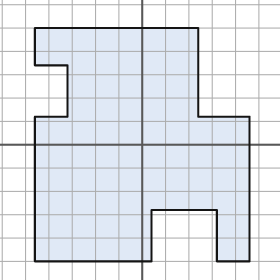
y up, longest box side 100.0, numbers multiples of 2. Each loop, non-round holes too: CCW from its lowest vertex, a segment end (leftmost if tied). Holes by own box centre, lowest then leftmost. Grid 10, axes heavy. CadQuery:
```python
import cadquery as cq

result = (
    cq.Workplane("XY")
    .moveTo(-46.0, -50.0)
    .lineTo(4.0, -50.0)
    .lineTo(4.0, -28.0)
    .lineTo(32.0, -28.0)
    .lineTo(32.0, -50.0)
    .lineTo(46.0, -50.0)
    .lineTo(46.0, 12.0)
    .lineTo(24.0, 12.0)
    .lineTo(24.0, 50.0)
    .lineTo(-46.0, 50.0)
    .lineTo(-46.0, 34.0)
    .lineTo(-32.0, 34.0)
    .lineTo(-32.0, 12.0)
    .lineTo(-46.0, 12.0)
    .close()
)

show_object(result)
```